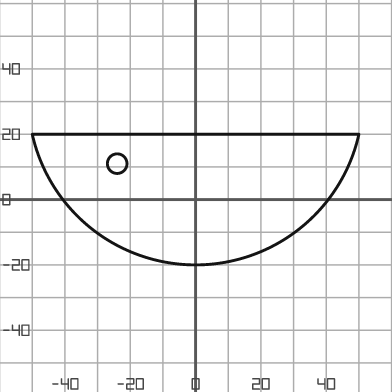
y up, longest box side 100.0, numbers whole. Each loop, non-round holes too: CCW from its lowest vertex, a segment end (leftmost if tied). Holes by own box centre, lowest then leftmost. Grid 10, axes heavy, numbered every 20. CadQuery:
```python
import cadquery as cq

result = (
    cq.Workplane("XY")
    .moveTo(-50.0, 20.0)
    .threePointArc((0.0, -20.0), (50.0, 20.0))
    .close()
    .moveTo(-24.0, 11.0)
    .circle(3.0)
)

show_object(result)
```